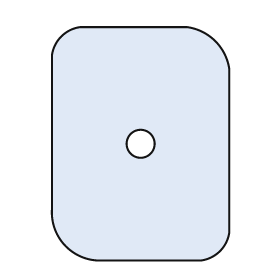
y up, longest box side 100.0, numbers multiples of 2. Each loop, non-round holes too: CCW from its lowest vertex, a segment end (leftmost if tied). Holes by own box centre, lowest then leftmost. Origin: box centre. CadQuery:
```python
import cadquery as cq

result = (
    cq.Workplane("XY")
    .moveTo(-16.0, -50.0)
    .lineTo(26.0, -50.0)
    .threePointArc((34.0, -46.0), (38.0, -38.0))
    .lineTo(38.0, 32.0)
    .threePointArc((32.0, 44.0), (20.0, 50.0))
    .lineTo(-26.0, 50.0)
    .threePointArc((-34.0, 46.0), (-38.0, 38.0))
    .lineTo(-38.0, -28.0)
    .threePointArc((-32.0, -44.0), (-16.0, -50.0))
    .close()
    .moveTo(0.0, 0.0)
    .circle(6.0)
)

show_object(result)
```